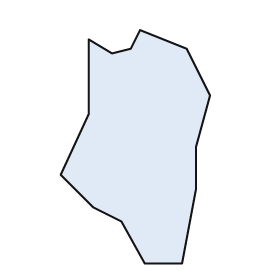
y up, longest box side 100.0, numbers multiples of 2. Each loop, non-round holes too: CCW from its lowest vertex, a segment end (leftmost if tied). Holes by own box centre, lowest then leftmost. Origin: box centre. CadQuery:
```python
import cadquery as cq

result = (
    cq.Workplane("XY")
    .moveTo(4.0, -50.0)
    .lineTo(20.0, -50.0)
    .lineTo(26.0, -18.0)
    .lineTo(26.0, 0.0)
    .lineTo(32.0, 22.0)
    .lineTo(22.0, 42.0)
    .lineTo(2.0, 50.0)
    .lineTo(-2.0, 42.0)
    .lineTo(-10.0, 40.0)
    .lineTo(-20.0, 46.0)
    .lineTo(-20.0, 14.0)
    .lineTo(-32.0, -12.0)
    .lineTo(-18.0, -26.0)
    .lineTo(-6.0, -32.0)
    .close()
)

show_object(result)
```